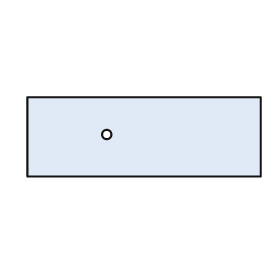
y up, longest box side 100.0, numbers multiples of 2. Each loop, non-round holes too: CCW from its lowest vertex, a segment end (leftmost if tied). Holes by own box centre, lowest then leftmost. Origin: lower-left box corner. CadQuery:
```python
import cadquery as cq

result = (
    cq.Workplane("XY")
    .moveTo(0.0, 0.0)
    .lineTo(100.0, 0.0)
    .lineTo(100.0, 34.0)
    .lineTo(0.0, 34.0)
    .close()
    .moveTo(34.0, 18.0)
    .circle(2.0)
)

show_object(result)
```